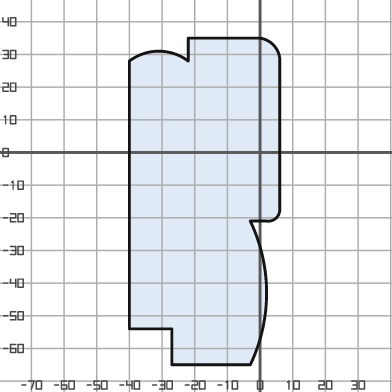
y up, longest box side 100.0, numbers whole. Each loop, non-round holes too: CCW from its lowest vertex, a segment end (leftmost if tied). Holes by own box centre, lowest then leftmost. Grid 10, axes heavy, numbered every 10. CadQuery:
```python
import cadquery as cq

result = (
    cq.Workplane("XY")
    .moveTo(-27.0, -65.0)
    .lineTo(-3.0, -65.0)
    .threePointArc((2.0, -43.0), (-3.0, -21.0))
    .lineTo(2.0, -21.0)
    .threePointArc((5.0, -20.0), (6.0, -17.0))
    .lineTo(6.0, 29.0)
    .threePointArc((4.0, 33.0), (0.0, 35.0))
    .lineTo(-22.0, 35.0)
    .lineTo(-22.0, 28.0)
    .threePointArc((-31.0, 31.0), (-40.0, 28.0))
    .lineTo(-40.0, -54.0)
    .lineTo(-27.0, -54.0)
    .close()
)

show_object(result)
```